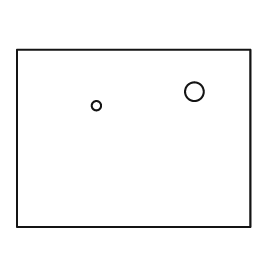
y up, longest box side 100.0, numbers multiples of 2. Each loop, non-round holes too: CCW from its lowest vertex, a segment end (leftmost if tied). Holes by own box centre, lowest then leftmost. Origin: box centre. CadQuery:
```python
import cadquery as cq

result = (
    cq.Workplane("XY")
    .moveTo(-50.0, -38.0)
    .lineTo(50.0, -38.0)
    .lineTo(50.0, 38.0)
    .lineTo(-50.0, 38.0)
    .close()
    .moveTo(-16.0, 14.0)
    .circle(2.0)
    .moveTo(26.0, 20.0)
    .circle(4.0)
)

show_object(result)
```